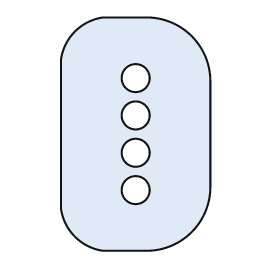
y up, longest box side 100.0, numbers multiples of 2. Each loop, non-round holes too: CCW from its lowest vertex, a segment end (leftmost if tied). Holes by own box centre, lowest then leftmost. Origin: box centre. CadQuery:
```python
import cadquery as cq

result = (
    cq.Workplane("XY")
    .moveTo(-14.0, -50.0)
    .lineTo(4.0, -50.0)
    .threePointArc((24.0, -42.0), (32.0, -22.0))
    .lineTo(32.0, 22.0)
    .threePointArc((24.0, 42.0), (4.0, 50.0))
    .lineTo(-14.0, 50.0)
    .threePointArc((-26.0, 44.0), (-32.0, 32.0))
    .lineTo(-32.0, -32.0)
    .threePointArc((-26.0, -44.0), (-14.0, -50.0))
    .close()
    .moveTo(0.0, -24.0)
    .circle(6.0)
    .moveTo(0.0, -8.0)
    .circle(6.0)
    .moveTo(0.0, 8.0)
    .circle(6.0)
    .moveTo(0.0, 24.0)
    .circle(6.0)
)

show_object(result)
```